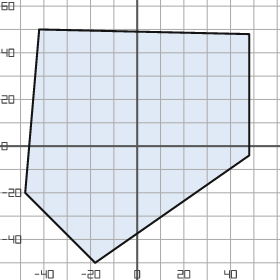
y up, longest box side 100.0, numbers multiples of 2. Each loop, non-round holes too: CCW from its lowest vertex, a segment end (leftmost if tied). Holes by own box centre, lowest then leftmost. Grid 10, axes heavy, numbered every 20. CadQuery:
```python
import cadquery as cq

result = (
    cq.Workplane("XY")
    .moveTo(-18.0, -50.0)
    .lineTo(48.0, -4.0)
    .lineTo(48.0, 48.0)
    .lineTo(-42.0, 50.0)
    .lineTo(-48.0, -20.0)
    .close()
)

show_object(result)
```